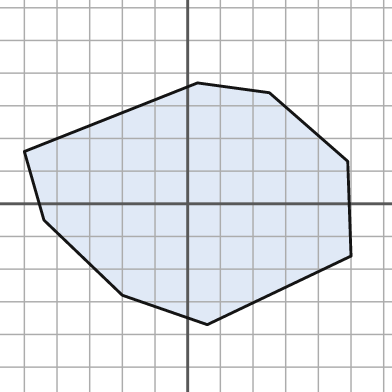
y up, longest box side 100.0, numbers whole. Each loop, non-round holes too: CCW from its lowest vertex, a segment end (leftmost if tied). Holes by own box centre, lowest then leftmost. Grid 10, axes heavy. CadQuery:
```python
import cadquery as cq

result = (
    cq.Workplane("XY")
    .moveTo(6.0, -37.0)
    .lineTo(50.0, -16.0)
    .lineTo(49.0, 13.0)
    .lineTo(25.0, 34.0)
    .lineTo(3.0, 37.0)
    .lineTo(-50.0, 16.0)
    .lineTo(-44.0, -5.0)
    .lineTo(-20.0, -28.0)
    .close()
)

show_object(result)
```